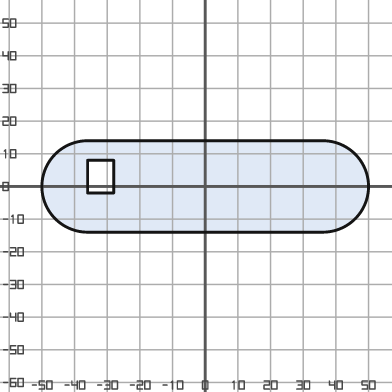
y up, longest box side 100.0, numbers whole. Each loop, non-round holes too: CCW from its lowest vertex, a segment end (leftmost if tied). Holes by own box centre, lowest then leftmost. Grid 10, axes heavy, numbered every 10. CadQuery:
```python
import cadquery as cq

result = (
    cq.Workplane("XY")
    .moveTo(-36.0, -14.0)
    .lineTo(36.0, -14.0)
    .threePointArc((50.0, 0.0), (36.0, 14.0))
    .lineTo(-36.0, 14.0)
    .threePointArc((-50.0, 0.0), (-36.0, -14.0))
    .close()
    .moveTo(-36.0, -2.0)
    .lineTo(-28.0, -2.0)
    .lineTo(-28.0, 8.0)
    .lineTo(-36.0, 8.0)
    .close()
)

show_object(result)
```